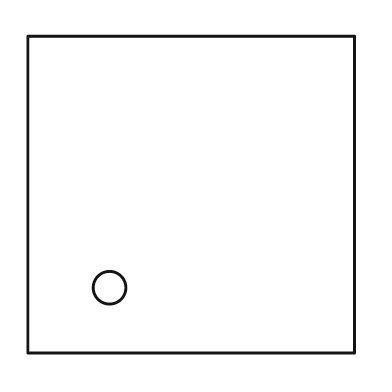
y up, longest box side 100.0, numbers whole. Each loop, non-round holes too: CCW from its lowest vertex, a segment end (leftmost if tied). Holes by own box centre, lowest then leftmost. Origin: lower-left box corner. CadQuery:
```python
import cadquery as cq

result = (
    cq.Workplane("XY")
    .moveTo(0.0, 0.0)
    .lineTo(100.0, 0.0)
    .lineTo(100.0, 97.0)
    .lineTo(0.0, 97.0)
    .close()
    .moveTo(25.0, 20.0)
    .circle(5.0)
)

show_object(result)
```